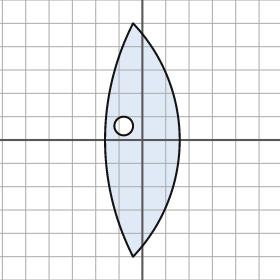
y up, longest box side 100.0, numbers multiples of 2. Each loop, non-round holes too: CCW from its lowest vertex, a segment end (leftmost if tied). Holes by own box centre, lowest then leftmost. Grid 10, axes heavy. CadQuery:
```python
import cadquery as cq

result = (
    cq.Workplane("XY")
    .moveTo(-4.0, -50.0)
    .threePointArc((16.0, 0.0), (-4.0, 50.0))
    .threePointArc((-16.0, 0.0), (-4.0, -50.0))
    .close()
    .moveTo(-8.0, 6.0)
    .circle(4.0)
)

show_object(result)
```